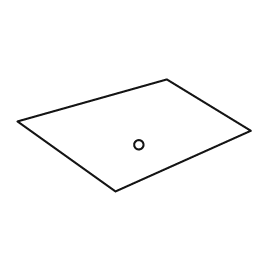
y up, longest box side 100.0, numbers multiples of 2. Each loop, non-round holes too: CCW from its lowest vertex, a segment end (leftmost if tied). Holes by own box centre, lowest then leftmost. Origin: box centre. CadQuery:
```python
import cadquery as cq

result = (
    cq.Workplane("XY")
    .moveTo(-8.0, -24.0)
    .lineTo(50.0, 2.0)
    .lineTo(14.0, 24.0)
    .lineTo(-50.0, 6.0)
    .close()
    .moveTo(2.0, -4.0)
    .circle(2.0)
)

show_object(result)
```